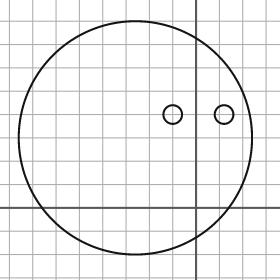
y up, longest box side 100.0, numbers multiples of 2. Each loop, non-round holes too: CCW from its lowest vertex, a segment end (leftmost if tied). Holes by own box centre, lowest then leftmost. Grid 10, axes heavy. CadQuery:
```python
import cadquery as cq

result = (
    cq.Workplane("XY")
    .moveTo(-26.0, 30.0)
    .circle(50.0)
    .moveTo(-10.0, 40.0)
    .circle(4.0)
    .moveTo(12.0, 40.0)
    .circle(4.0)
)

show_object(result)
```